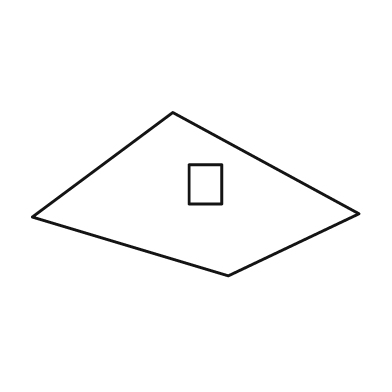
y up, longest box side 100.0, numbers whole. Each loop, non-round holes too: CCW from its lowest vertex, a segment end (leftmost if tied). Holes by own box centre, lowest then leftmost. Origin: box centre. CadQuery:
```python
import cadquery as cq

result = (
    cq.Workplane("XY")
    .moveTo(10.0, -25.0)
    .lineTo(50.0, -6.0)
    .lineTo(-7.0, 25.0)
    .lineTo(-50.0, -7.0)
    .close()
    .moveTo(-2.0, -3.0)
    .lineTo(8.0, -3.0)
    .lineTo(8.0, 9.0)
    .lineTo(-2.0, 9.0)
    .close()
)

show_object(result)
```